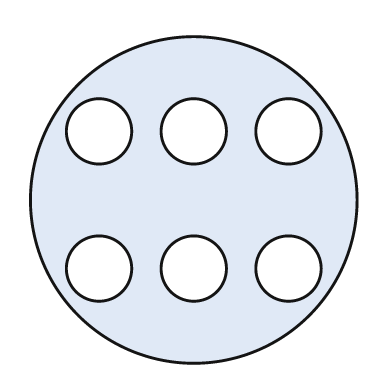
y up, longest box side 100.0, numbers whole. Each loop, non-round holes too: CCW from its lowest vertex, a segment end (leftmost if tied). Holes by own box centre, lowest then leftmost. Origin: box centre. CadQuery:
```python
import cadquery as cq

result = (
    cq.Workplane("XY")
    .moveTo(0.0, 0.0)
    .circle(50.0)
    .moveTo(-29.0, -21.0)
    .circle(10.0)
    .moveTo(0.0, -21.0)
    .circle(10.0)
    .moveTo(29.0, -21.0)
    .circle(10.0)
    .moveTo(-29.0, 21.0)
    .circle(10.0)
    .moveTo(0.0, 21.0)
    .circle(10.0)
    .moveTo(29.0, 21.0)
    .circle(10.0)
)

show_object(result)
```